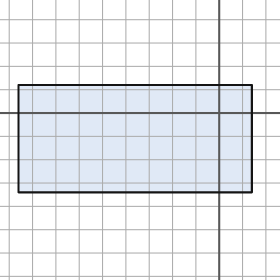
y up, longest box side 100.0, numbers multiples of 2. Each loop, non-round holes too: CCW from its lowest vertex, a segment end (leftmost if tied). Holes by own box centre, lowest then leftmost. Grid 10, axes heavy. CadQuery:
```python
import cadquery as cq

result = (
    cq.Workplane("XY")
    .moveTo(-86.0, -34.0)
    .lineTo(14.0, -34.0)
    .lineTo(14.0, 12.0)
    .lineTo(-86.0, 12.0)
    .close()
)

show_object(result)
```